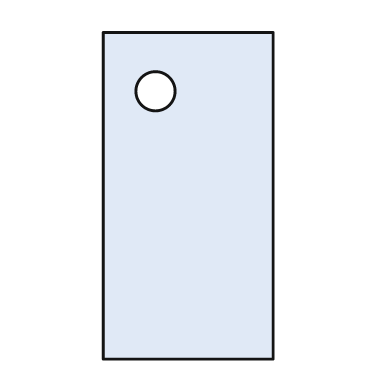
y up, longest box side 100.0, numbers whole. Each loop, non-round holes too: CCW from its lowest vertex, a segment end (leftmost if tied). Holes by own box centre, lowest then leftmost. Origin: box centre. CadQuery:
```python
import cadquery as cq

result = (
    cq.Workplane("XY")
    .moveTo(-26.0, -50.0)
    .lineTo(26.0, -50.0)
    .lineTo(26.0, 50.0)
    .lineTo(-26.0, 50.0)
    .close()
    .moveTo(-10.0, 32.0)
    .circle(6.0)
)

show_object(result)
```